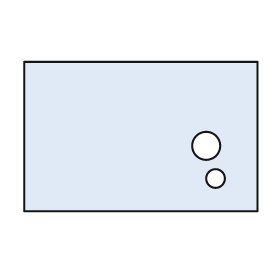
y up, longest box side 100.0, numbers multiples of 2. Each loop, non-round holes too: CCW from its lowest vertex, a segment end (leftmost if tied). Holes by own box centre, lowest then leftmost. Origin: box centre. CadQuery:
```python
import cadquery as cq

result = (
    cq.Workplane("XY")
    .moveTo(-50.0, -32.0)
    .lineTo(50.0, -32.0)
    .lineTo(50.0, 32.0)
    .lineTo(-50.0, 32.0)
    .close()
    .moveTo(32.0, -18.0)
    .circle(4.0)
    .moveTo(28.0, -4.0)
    .circle(6.0)
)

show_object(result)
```